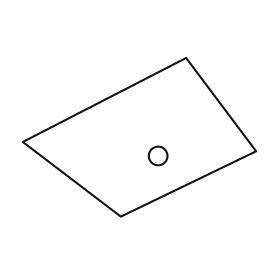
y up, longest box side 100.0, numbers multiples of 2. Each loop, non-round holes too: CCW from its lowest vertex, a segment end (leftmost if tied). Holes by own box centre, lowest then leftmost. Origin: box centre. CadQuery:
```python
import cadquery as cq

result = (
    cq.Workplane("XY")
    .moveTo(-8.0, -34.0)
    .lineTo(50.0, -6.0)
    .lineTo(20.0, 34.0)
    .lineTo(-50.0, -2.0)
    .close()
    .moveTo(8.0, -8.0)
    .circle(4.0)
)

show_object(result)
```